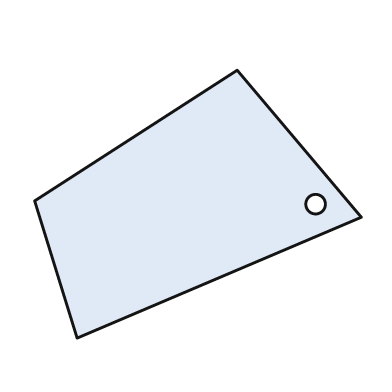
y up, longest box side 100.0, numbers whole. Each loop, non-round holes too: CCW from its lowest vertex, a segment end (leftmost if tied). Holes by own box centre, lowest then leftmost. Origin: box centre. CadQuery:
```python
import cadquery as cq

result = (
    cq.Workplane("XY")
    .moveTo(-37.0, -41.0)
    .lineTo(50.0, -4.0)
    .lineTo(12.0, 41.0)
    .lineTo(-50.0, 1.0)
    .close()
    .moveTo(36.0, 0.0)
    .circle(3.0)
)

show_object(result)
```